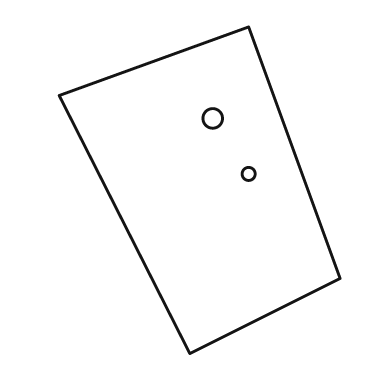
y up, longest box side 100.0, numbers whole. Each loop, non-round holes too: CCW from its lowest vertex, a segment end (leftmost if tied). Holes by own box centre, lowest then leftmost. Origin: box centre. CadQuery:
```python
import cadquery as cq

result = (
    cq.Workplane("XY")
    .moveTo(-3.0, -50.0)
    .lineTo(43.0, -27.0)
    .lineTo(15.0, 50.0)
    .lineTo(-43.0, 29.0)
    .close()
    .moveTo(15.0, 5.0)
    .circle(2.0)
    .moveTo(4.0, 22.0)
    .circle(3.0)
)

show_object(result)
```